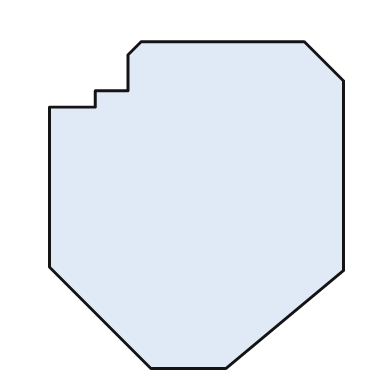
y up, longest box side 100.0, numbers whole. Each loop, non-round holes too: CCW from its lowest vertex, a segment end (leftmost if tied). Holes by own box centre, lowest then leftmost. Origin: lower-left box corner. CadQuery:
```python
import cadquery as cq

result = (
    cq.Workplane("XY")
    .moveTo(31.0, 0.0)
    .lineTo(54.0, 0.0)
    .lineTo(90.0, 30.0)
    .lineTo(90.0, 88.0)
    .lineTo(78.0, 100.0)
    .lineTo(28.0, 100.0)
    .lineTo(24.0, 96.0)
    .lineTo(24.0, 85.0)
    .lineTo(14.0, 85.0)
    .lineTo(14.0, 80.0)
    .lineTo(0.0, 80.0)
    .lineTo(0.0, 31.0)
    .close()
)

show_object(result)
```